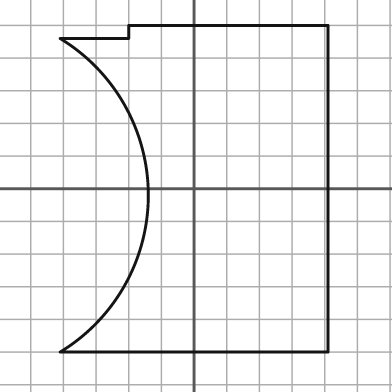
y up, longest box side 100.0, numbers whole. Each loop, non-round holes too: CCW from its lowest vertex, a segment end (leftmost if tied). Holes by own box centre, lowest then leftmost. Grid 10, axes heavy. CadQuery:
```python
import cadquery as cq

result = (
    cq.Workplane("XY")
    .moveTo(-41.0, -50.0)
    .lineTo(41.0, -50.0)
    .lineTo(41.0, 50.0)
    .lineTo(-20.0, 50.0)
    .lineTo(-20.0, 46.0)
    .lineTo(-41.0, 46.0)
    .threePointArc((-14.0, -2.0), (-41.0, -50.0))
    .close()
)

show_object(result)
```